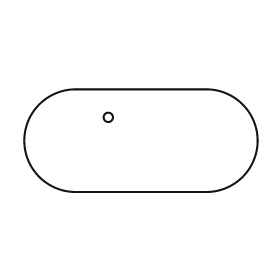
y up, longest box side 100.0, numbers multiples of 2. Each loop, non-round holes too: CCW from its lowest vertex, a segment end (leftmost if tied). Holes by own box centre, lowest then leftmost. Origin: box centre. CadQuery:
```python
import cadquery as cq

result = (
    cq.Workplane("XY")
    .moveTo(-28.0, -22.0)
    .lineTo(28.0, -22.0)
    .threePointArc((50.0, 0.0), (28.0, 22.0))
    .lineTo(-28.0, 22.0)
    .threePointArc((-50.0, 0.0), (-28.0, -22.0))
    .close()
    .moveTo(-14.0, 10.0)
    .circle(2.0)
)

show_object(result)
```